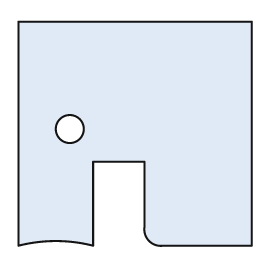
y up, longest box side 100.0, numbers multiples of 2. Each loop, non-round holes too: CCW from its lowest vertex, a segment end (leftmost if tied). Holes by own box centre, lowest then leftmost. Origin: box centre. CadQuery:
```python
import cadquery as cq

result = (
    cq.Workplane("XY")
    .moveTo(-50.0, -48.0)
    .threePointArc((-34.0, -46.0), (-18.0, -48.0))
    .lineTo(-18.0, -12.0)
    .lineTo(4.0, -12.0)
    .lineTo(4.0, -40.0)
    .threePointArc((6.0, -46.0), (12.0, -48.0))
    .lineTo(50.0, -48.0)
    .lineTo(50.0, 48.0)
    .lineTo(-50.0, 48.0)
    .close()
    .moveTo(-28.0, 2.0)
    .circle(6.0)
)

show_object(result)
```